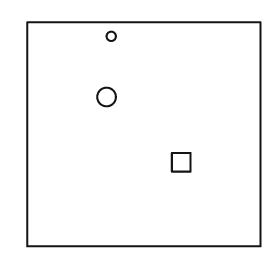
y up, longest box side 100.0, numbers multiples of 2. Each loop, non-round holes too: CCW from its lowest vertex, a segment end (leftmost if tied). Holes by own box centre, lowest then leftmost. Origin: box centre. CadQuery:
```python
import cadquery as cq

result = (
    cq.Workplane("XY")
    .moveTo(-50.0, -48.0)
    .lineTo(50.0, -48.0)
    .lineTo(50.0, 48.0)
    .lineTo(-50.0, 48.0)
    .close()
    .moveTo(12.0, -16.0)
    .lineTo(20.0, -16.0)
    .lineTo(20.0, -8.0)
    .lineTo(12.0, -8.0)
    .close()
    .moveTo(-16.0, 16.0)
    .circle(4.0)
    .moveTo(-14.0, 42.0)
    .circle(2.0)
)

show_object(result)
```